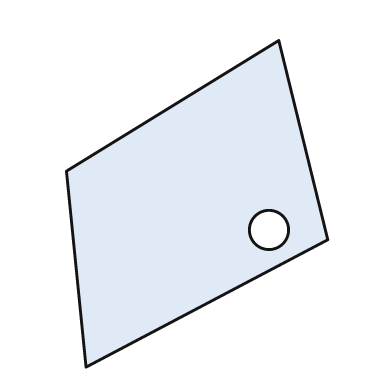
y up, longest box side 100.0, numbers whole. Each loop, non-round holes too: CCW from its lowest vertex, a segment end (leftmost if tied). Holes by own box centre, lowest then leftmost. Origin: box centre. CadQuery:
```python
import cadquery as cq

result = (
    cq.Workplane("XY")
    .moveTo(-34.0, -50.0)
    .lineTo(40.0, -11.0)
    .lineTo(25.0, 50.0)
    .lineTo(-40.0, 10.0)
    .close()
    .moveTo(22.0, -8.0)
    .circle(6.0)
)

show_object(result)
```